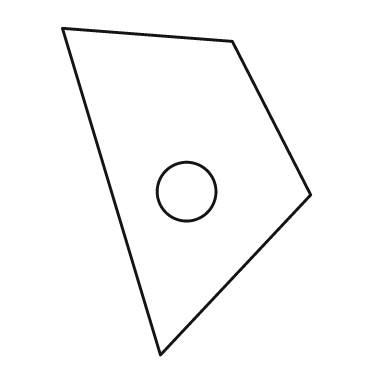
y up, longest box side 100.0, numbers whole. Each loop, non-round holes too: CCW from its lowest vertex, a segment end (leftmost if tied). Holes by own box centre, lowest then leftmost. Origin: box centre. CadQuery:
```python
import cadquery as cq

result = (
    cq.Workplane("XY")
    .moveTo(-8.0, -50.0)
    .lineTo(38.0, -1.0)
    .lineTo(14.0, 46.0)
    .lineTo(-38.0, 50.0)
    .close()
    .moveTo(0.0, 0.0)
    .circle(9.0)
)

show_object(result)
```